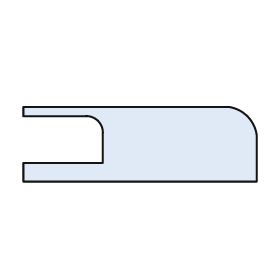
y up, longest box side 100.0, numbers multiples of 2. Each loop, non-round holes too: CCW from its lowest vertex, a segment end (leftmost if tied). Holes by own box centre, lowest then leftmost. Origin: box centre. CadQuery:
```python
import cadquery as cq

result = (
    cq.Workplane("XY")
    .moveTo(-50.0, -16.0)
    .lineTo(50.0, -16.0)
    .lineTo(50.0, 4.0)
    .threePointArc((46.0, 12.0), (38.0, 16.0))
    .lineTo(-50.0, 16.0)
    .lineTo(-50.0, 12.0)
    .lineTo(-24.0, 12.0)
    .threePointArc((-18.0, 10.0), (-16.0, 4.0))
    .lineTo(-16.0, -8.0)
    .lineTo(-50.0, -8.0)
    .close()
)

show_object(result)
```